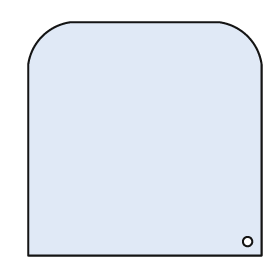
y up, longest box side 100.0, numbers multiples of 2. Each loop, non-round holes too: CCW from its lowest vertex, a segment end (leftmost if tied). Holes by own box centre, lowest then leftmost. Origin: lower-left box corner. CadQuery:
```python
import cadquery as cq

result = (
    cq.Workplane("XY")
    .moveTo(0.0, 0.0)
    .lineTo(100.0, 0.0)
    .lineTo(100.0, 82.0)
    .threePointArc((94.0, 94.0), (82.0, 100.0))
    .lineTo(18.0, 100.0)
    .threePointArc((6.0, 94.0), (0.0, 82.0))
    .close()
    .moveTo(94.0, 6.0)
    .circle(2.0)
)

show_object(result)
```